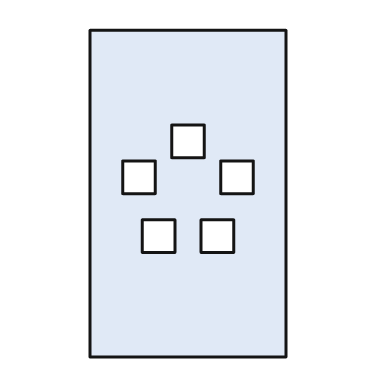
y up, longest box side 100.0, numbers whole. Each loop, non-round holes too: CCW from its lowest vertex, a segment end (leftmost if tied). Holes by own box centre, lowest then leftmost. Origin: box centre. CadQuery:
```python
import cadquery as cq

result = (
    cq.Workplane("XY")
    .moveTo(-30.0, -50.0)
    .lineTo(30.0, -50.0)
    .lineTo(30.0, 50.0)
    .lineTo(-30.0, 50.0)
    .close()
    .moveTo(-14.0, -18.0)
    .lineTo(-4.0, -18.0)
    .lineTo(-4.0, -8.0)
    .lineTo(-14.0, -8.0)
    .close()
    .moveTo(4.0, -18.0)
    .lineTo(14.0, -18.0)
    .lineTo(14.0, -8.0)
    .lineTo(4.0, -8.0)
    .close()
    .moveTo(-20.0, 0.0)
    .lineTo(-10.0, 0.0)
    .lineTo(-10.0, 10.0)
    .lineTo(-20.0, 10.0)
    .close()
    .moveTo(10.0, 0.0)
    .lineTo(20.0, 0.0)
    .lineTo(20.0, 10.0)
    .lineTo(10.0, 10.0)
    .close()
    .moveTo(-5.0, 11.0)
    .lineTo(5.0, 11.0)
    .lineTo(5.0, 21.0)
    .lineTo(-5.0, 21.0)
    .close()
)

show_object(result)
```